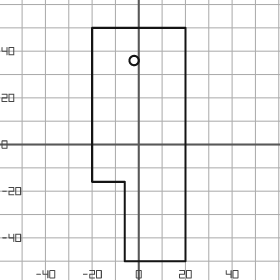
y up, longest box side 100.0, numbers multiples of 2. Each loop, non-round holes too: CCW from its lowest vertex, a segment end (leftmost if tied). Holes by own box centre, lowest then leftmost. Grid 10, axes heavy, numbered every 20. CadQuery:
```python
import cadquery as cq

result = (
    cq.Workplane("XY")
    .moveTo(-6.0, -50.0)
    .lineTo(20.0, -50.0)
    .lineTo(20.0, 50.0)
    .lineTo(-20.0, 50.0)
    .lineTo(-20.0, -16.0)
    .lineTo(-6.0, -16.0)
    .close()
    .moveTo(-2.0, 36.0)
    .circle(2.0)
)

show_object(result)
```